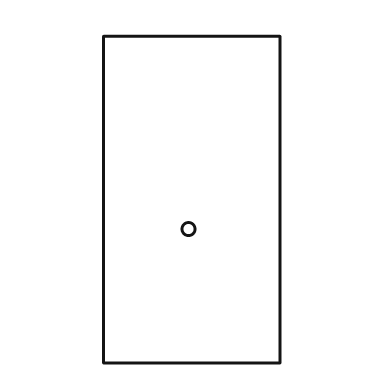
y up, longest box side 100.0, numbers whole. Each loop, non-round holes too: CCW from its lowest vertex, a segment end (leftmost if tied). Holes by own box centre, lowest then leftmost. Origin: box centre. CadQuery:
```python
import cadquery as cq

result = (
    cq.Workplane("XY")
    .moveTo(-27.0, -50.0)
    .lineTo(27.0, -50.0)
    .lineTo(27.0, 50.0)
    .lineTo(-27.0, 50.0)
    .close()
    .moveTo(-1.0, -9.0)
    .circle(2.0)
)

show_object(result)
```